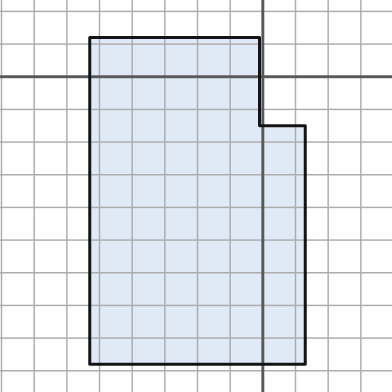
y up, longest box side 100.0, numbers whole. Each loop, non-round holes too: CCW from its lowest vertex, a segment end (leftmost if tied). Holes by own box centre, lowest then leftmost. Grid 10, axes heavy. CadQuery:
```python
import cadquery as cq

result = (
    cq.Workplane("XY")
    .moveTo(-53.0, -88.0)
    .lineTo(13.0, -88.0)
    .lineTo(13.0, -15.0)
    .lineTo(-1.0, -15.0)
    .lineTo(-1.0, 12.0)
    .lineTo(-53.0, 12.0)
    .close()
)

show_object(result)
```